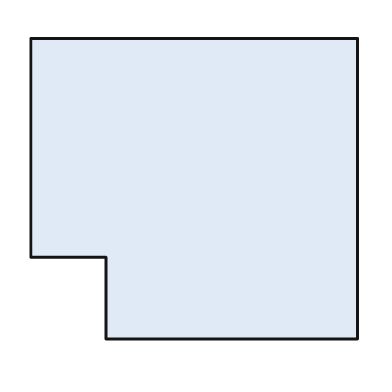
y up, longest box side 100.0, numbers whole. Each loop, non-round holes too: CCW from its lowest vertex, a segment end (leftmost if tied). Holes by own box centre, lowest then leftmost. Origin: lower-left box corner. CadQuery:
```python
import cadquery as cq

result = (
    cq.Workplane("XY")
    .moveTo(23.0, 0.0)
    .lineTo(100.0, 0.0)
    .lineTo(100.0, 92.0)
    .lineTo(0.0, 92.0)
    .lineTo(0.0, 25.0)
    .lineTo(23.0, 25.0)
    .close()
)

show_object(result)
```